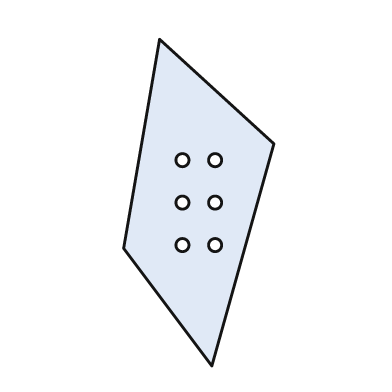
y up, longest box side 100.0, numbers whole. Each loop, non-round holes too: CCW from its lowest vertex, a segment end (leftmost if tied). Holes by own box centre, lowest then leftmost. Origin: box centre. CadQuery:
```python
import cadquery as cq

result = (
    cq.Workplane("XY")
    .moveTo(4.0, -50.0)
    .lineTo(23.0, 18.0)
    .lineTo(-12.0, 50.0)
    .lineTo(-23.0, -14.0)
    .close()
    .moveTo(-5.0, -13.0)
    .circle(2.0)
    .moveTo(5.0, -13.0)
    .circle(2.0)
    .moveTo(-5.0, 0.0)
    .circle(2.0)
    .moveTo(5.0, 0.0)
    .circle(2.0)
    .moveTo(-5.0, 13.0)
    .circle(2.0)
    .moveTo(5.0, 13.0)
    .circle(2.0)
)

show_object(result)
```